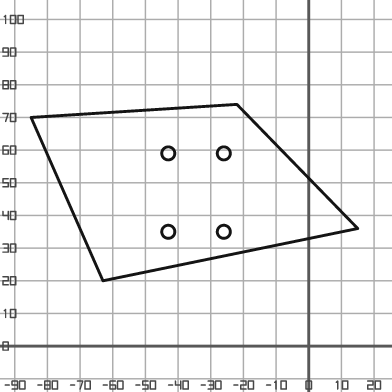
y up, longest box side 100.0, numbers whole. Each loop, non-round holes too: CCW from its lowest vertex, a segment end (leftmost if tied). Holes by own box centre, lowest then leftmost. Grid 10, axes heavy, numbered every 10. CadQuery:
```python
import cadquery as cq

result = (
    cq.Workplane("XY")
    .moveTo(-63.0, 20.0)
    .lineTo(15.0, 36.0)
    .lineTo(-22.0, 74.0)
    .lineTo(-85.0, 70.0)
    .close()
    .moveTo(-43.0, 35.0)
    .circle(2.0)
    .moveTo(-26.0, 35.0)
    .circle(2.0)
    .moveTo(-43.0, 59.0)
    .circle(2.0)
    .moveTo(-26.0, 59.0)
    .circle(2.0)
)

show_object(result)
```